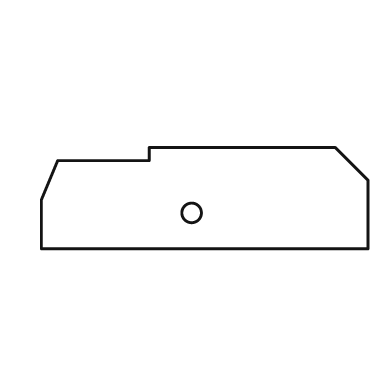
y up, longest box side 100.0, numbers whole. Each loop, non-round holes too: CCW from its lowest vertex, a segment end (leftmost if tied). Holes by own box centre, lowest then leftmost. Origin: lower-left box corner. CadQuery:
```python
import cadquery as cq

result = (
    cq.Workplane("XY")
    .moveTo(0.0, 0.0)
    .lineTo(100.0, 0.0)
    .lineTo(100.0, 21.0)
    .lineTo(90.0, 31.0)
    .lineTo(33.0, 31.0)
    .lineTo(33.0, 27.0)
    .lineTo(5.0, 27.0)
    .lineTo(0.0, 15.0)
    .close()
    .moveTo(46.0, 11.0)
    .circle(3.0)
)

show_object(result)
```